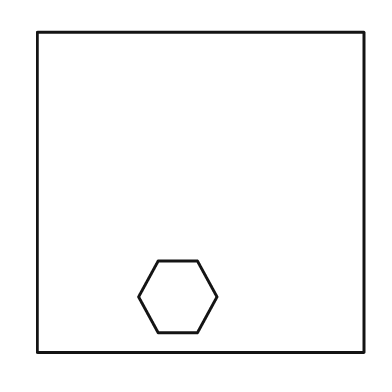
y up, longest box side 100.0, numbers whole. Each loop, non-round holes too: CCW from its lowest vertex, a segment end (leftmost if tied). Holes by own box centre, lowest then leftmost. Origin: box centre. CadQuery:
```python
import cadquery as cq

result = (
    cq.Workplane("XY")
    .moveTo(-50.0, -49.0)
    .lineTo(50.0, -49.0)
    .lineTo(50.0, 49.0)
    .lineTo(-50.0, 49.0)
    .close()
    .moveTo(-13.0, -43.0)
    .lineTo(-1.0, -43.0)
    .lineTo(5.0, -32.0)
    .lineTo(-1.0, -21.0)
    .lineTo(-13.0, -21.0)
    .lineTo(-19.0, -32.0)
    .close()
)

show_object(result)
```